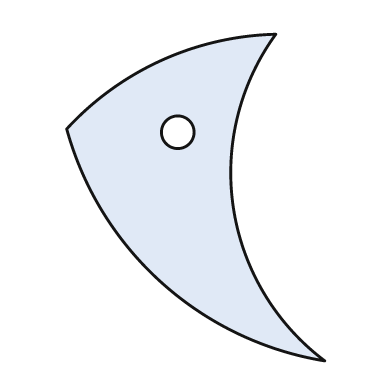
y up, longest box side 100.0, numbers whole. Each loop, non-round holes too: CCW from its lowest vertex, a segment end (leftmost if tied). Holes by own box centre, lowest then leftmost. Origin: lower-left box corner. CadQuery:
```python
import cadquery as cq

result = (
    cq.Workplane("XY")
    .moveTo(79.0, 0.0)
    .threePointArc((51.0, 47.0), (64.0, 100.0))
    .threePointArc((29.0, 92.0), (0.0, 71.0))
    .threePointArc((29.0, 24.0), (79.0, 0.0))
    .close()
    .moveTo(34.0, 70.0)
    .circle(5.0)
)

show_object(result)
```